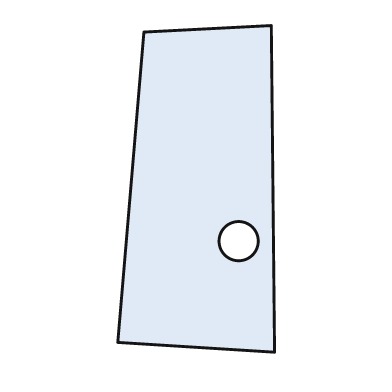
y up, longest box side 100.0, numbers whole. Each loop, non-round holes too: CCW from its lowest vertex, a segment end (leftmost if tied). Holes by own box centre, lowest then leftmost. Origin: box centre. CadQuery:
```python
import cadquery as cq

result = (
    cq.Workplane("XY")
    .moveTo(24.0, -50.0)
    .lineTo(23.0, 50.0)
    .lineTo(-16.0, 48.0)
    .lineTo(-24.0, -47.0)
    .close()
    .moveTo(13.0, -16.0)
    .circle(6.0)
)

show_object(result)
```